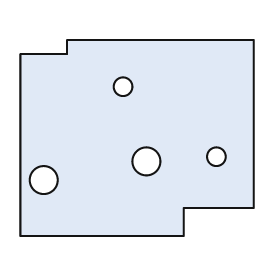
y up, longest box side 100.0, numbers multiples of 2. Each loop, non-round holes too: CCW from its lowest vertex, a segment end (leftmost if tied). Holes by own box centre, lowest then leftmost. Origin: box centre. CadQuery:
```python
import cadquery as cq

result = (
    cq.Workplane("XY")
    .moveTo(-50.0, -42.0)
    .lineTo(20.0, -42.0)
    .lineTo(20.0, -30.0)
    .lineTo(50.0, -30.0)
    .lineTo(50.0, 42.0)
    .lineTo(-30.0, 42.0)
    .lineTo(-30.0, 36.0)
    .lineTo(-50.0, 36.0)
    .close()
    .moveTo(-40.0, -18.0)
    .circle(6.0)
    .moveTo(4.0, -10.0)
    .circle(6.0)
    .moveTo(34.0, -8.0)
    .circle(4.0)
    .moveTo(-6.0, 22.0)
    .circle(4.0)
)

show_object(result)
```